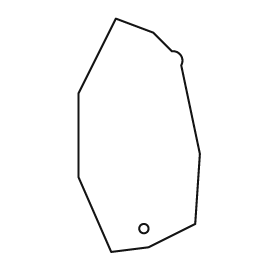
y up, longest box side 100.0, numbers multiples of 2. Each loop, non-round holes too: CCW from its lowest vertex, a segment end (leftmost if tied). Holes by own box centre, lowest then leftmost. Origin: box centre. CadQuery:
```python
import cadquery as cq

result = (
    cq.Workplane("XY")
    .moveTo(-12.0, -50.0)
    .lineTo(4.0, -48.0)
    .lineTo(24.0, -38.0)
    .lineTo(26.0, -8.0)
    .lineTo(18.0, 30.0)
    .threePointArc((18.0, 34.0), (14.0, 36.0))
    .lineTo(6.0, 44.0)
    .lineTo(-10.0, 50.0)
    .lineTo(-26.0, 18.0)
    .lineTo(-26.0, -18.0)
    .close()
    .moveTo(2.0, -40.0)
    .circle(2.0)
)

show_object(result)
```